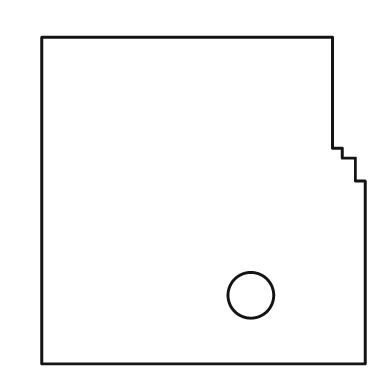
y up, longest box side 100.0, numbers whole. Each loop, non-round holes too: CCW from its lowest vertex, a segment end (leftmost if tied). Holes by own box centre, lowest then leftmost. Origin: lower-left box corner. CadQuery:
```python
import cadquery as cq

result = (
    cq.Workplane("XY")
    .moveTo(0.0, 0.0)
    .lineTo(99.0, 0.0)
    .lineTo(99.0, 56.0)
    .lineTo(96.0, 56.0)
    .lineTo(96.0, 63.0)
    .lineTo(92.0, 63.0)
    .lineTo(92.0, 66.0)
    .lineTo(89.0, 66.0)
    .lineTo(89.0, 100.0)
    .lineTo(0.0, 100.0)
    .close()
    .moveTo(64.0, 21.0)
    .circle(7.0)
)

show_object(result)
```